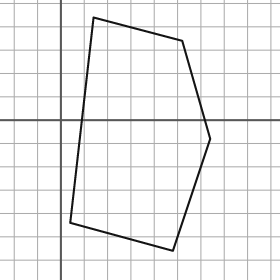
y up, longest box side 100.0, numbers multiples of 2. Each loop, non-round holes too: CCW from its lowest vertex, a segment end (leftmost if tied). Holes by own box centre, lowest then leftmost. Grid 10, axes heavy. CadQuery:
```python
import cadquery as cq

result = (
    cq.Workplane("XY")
    .moveTo(48.0, -56.0)
    .lineTo(64.0, -8.0)
    .lineTo(52.0, 34.0)
    .lineTo(14.0, 44.0)
    .lineTo(4.0, -44.0)
    .close()
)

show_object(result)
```